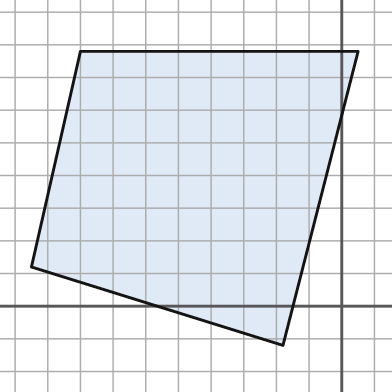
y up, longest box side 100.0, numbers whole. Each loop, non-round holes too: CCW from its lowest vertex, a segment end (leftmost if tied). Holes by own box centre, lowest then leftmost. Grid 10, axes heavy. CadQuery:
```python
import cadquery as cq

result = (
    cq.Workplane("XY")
    .moveTo(-18.0, -12.0)
    .lineTo(5.0, 78.0)
    .lineTo(-80.0, 78.0)
    .lineTo(-95.0, 12.0)
    .close()
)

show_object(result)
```